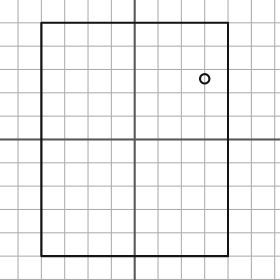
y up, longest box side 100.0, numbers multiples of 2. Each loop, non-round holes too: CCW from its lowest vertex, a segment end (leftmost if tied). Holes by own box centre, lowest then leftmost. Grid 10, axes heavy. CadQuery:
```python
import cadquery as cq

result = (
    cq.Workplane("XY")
    .moveTo(-40.0, -50.0)
    .lineTo(40.0, -50.0)
    .lineTo(40.0, 50.0)
    .lineTo(-40.0, 50.0)
    .close()
    .moveTo(30.0, 26.0)
    .circle(2.0)
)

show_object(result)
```